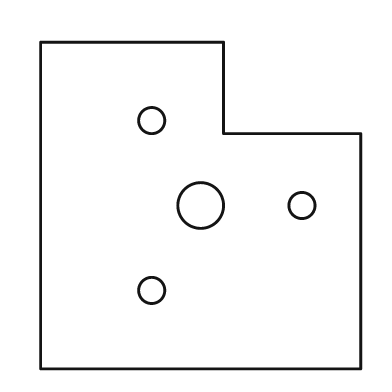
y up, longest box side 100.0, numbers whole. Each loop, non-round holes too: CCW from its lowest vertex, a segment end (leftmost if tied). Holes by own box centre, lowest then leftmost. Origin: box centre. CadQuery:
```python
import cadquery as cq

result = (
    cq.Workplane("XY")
    .moveTo(-49.0, -50.0)
    .lineTo(49.0, -50.0)
    .lineTo(49.0, 22.0)
    .lineTo(7.0, 22.0)
    .lineTo(7.0, 50.0)
    .lineTo(-49.0, 50.0)
    .close()
    .moveTo(-15.0, -26.0)
    .circle(4.0)
    .moveTo(0.0, 0.0)
    .circle(7.0)
    .moveTo(31.0, 0.0)
    .circle(4.0)
    .moveTo(-15.0, 26.0)
    .circle(4.0)
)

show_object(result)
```